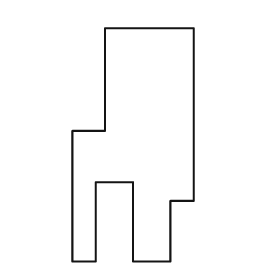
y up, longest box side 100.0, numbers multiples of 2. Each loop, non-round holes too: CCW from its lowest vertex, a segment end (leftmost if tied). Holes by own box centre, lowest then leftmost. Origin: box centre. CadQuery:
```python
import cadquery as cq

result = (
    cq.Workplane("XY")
    .moveTo(-26.0, -50.0)
    .lineTo(-16.0, -50.0)
    .lineTo(-16.0, -16.0)
    .lineTo(0.0, -16.0)
    .lineTo(0.0, -50.0)
    .lineTo(16.0, -50.0)
    .lineTo(16.0, -24.0)
    .lineTo(26.0, -24.0)
    .lineTo(26.0, 50.0)
    .lineTo(-12.0, 50.0)
    .lineTo(-12.0, 6.0)
    .lineTo(-26.0, 6.0)
    .close()
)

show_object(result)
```